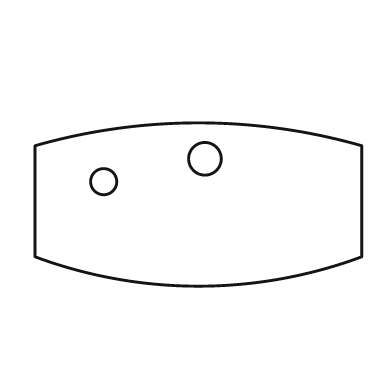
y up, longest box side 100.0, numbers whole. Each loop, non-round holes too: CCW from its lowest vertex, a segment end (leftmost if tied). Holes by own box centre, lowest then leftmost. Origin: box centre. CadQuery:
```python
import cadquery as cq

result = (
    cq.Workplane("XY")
    .moveTo(-50.0, -16.0)
    .threePointArc((0.0, -25.0), (50.0, -16.0))
    .lineTo(50.0, 18.0)
    .threePointArc((0.0, 25.0), (-50.0, 18.0))
    .close()
    .moveTo(-29.0, 7.0)
    .circle(4.0)
    .moveTo(2.0, 14.0)
    .circle(5.0)
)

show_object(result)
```